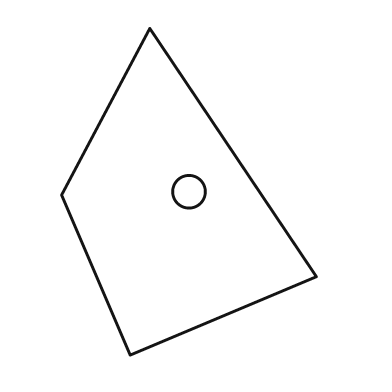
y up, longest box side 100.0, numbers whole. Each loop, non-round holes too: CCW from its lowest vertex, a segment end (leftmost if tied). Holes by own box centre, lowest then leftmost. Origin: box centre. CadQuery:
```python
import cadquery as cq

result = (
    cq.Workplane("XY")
    .moveTo(-18.0, -50.0)
    .lineTo(39.0, -26.0)
    .lineTo(-12.0, 50.0)
    .lineTo(-39.0, -1.0)
    .close()
    .moveTo(0.0, 0.0)
    .circle(5.0)
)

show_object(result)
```